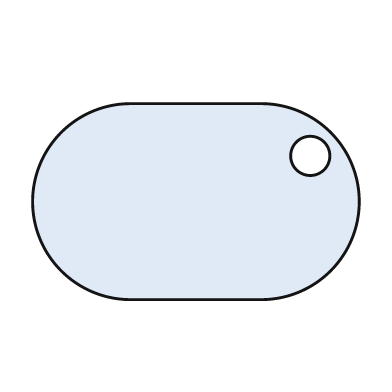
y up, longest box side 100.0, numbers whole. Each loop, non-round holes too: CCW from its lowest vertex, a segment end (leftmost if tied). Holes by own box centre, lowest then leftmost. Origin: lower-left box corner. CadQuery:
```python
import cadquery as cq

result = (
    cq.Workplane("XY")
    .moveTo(30.0, 0.0)
    .lineTo(70.0, 0.0)
    .threePointArc((100.0, 30.0), (70.0, 60.0))
    .lineTo(30.0, 60.0)
    .threePointArc((0.0, 30.0), (30.0, 0.0))
    .close()
    .moveTo(85.0, 44.0)
    .circle(6.0)
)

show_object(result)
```